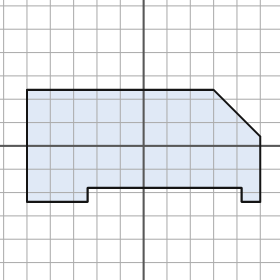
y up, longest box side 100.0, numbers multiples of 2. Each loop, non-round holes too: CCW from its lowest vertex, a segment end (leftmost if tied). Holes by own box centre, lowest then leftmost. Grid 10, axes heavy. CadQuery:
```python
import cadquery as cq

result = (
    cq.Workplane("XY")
    .moveTo(-50.0, -24.0)
    .lineTo(-24.0, -24.0)
    .lineTo(-24.0, -18.0)
    .lineTo(42.0, -18.0)
    .lineTo(42.0, -24.0)
    .lineTo(50.0, -24.0)
    .lineTo(50.0, 4.0)
    .lineTo(30.0, 24.0)
    .lineTo(-50.0, 24.0)
    .close()
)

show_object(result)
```